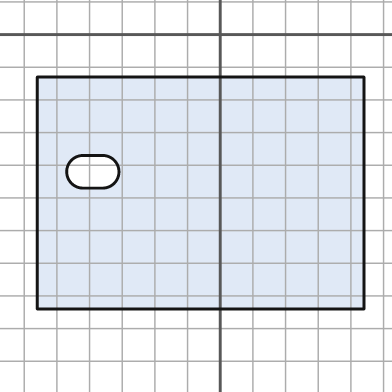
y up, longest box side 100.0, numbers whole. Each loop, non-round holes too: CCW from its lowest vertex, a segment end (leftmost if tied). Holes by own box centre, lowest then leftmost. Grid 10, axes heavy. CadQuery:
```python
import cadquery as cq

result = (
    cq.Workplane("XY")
    .moveTo(-56.0, -84.0)
    .lineTo(44.0, -84.0)
    .lineTo(44.0, -13.0)
    .lineTo(-56.0, -13.0)
    .close()
    .moveTo(-42.0, -47.0)
    .lineTo(-36.0, -47.0)
    .threePointArc((-31.0, -42.0), (-36.0, -37.0))
    .lineTo(-42.0, -37.0)
    .threePointArc((-47.0, -42.0), (-42.0, -47.0))
    .close()
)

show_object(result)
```